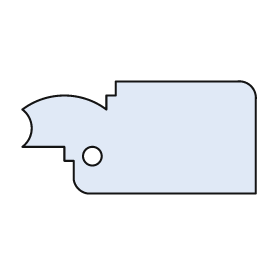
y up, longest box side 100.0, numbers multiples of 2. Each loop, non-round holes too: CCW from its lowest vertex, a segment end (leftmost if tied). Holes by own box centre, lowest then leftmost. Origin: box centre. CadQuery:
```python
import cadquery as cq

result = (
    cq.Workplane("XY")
    .moveTo(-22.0, -24.0)
    .lineTo(50.0, -24.0)
    .lineTo(50.0, 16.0)
    .threePointArc((48.0, 22.0), (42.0, 24.0))
    .lineTo(-10.0, 24.0)
    .lineTo(-10.0, 18.0)
    .lineTo(-14.0, 18.0)
    .lineTo(-14.0, 12.0)
    .threePointArc((-32.0, 18.0), (-50.0, 12.0))
    .threePointArc((-46.0, 4.0), (-50.0, -4.0))
    .lineTo(-32.0, -4.0)
    .lineTo(-32.0, -10.0)
    .lineTo(-28.0, -10.0)
    .lineTo(-28.0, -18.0)
    .threePointArc((-26.0, -22.0), (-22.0, -24.0))
    .close()
    .moveTo(-20.0, -8.0)
    .circle(4.0)
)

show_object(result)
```